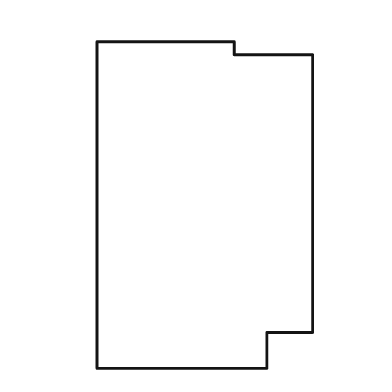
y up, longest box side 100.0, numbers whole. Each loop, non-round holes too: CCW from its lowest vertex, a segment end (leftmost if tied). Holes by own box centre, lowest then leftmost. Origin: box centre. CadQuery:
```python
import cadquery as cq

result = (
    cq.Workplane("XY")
    .moveTo(-33.0, -50.0)
    .lineTo(19.0, -50.0)
    .lineTo(19.0, -39.0)
    .lineTo(33.0, -39.0)
    .lineTo(33.0, 46.0)
    .lineTo(9.0, 46.0)
    .lineTo(9.0, 50.0)
    .lineTo(-33.0, 50.0)
    .close()
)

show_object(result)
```